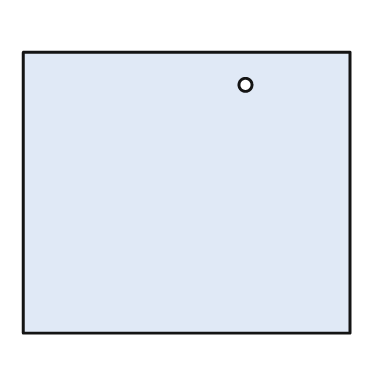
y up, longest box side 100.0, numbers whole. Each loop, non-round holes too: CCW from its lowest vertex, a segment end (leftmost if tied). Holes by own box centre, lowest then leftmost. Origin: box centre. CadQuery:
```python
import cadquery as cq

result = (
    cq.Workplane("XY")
    .moveTo(-50.0, -43.0)
    .lineTo(50.0, -43.0)
    .lineTo(50.0, 43.0)
    .lineTo(-50.0, 43.0)
    .close()
    .moveTo(18.0, 33.0)
    .circle(2.0)
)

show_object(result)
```